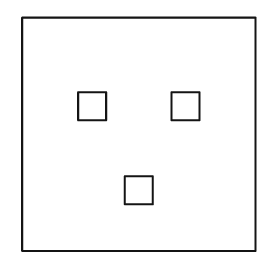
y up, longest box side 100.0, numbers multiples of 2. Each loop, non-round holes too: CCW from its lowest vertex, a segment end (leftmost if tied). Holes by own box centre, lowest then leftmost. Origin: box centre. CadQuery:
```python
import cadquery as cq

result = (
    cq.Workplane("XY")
    .moveTo(-50.0, -50.0)
    .lineTo(50.0, -50.0)
    .lineTo(50.0, 50.0)
    .lineTo(-50.0, 50.0)
    .close()
    .moveTo(-6.0, -30.0)
    .lineTo(6.0, -30.0)
    .lineTo(6.0, -18.0)
    .lineTo(-6.0, -18.0)
    .close()
    .moveTo(-26.0, 6.0)
    .lineTo(-14.0, 6.0)
    .lineTo(-14.0, 18.0)
    .lineTo(-26.0, 18.0)
    .close()
    .moveTo(14.0, 6.0)
    .lineTo(26.0, 6.0)
    .lineTo(26.0, 18.0)
    .lineTo(14.0, 18.0)
    .close()
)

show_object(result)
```